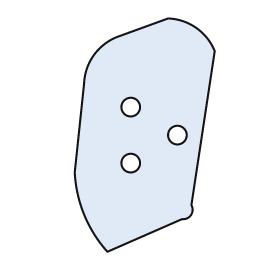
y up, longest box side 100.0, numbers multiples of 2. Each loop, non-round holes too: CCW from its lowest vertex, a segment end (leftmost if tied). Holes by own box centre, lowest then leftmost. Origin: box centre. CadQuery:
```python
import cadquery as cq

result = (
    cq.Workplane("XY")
    .moveTo(-16.0, -50.0)
    .lineTo(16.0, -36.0)
    .threePointArc((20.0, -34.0), (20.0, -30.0))
    .lineTo(30.0, 36.0)
    .threePointArc((22.0, 46.0), (10.0, 50.0))
    .lineTo(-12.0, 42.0)
    .threePointArc((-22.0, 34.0), (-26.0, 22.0))
    .lineTo(-30.0, -16.0)
    .threePointArc((-26.0, -34.0), (-16.0, -50.0))
    .close()
    .moveTo(-6.0, -12.0)
    .circle(4.0)
    .moveTo(14.0, 0.0)
    .circle(4.0)
    .moveTo(-6.0, 12.0)
    .circle(4.0)
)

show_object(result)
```